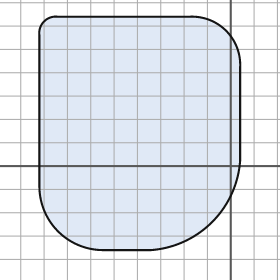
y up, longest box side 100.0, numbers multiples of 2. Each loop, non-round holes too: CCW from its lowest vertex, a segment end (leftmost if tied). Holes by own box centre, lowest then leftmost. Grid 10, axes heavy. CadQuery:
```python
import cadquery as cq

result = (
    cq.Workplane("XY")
    .moveTo(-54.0, -36.0)
    .lineTo(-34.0, -36.0)
    .threePointArc((-8.0, -24.0), (4.0, 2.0))
    .lineTo(4.0, 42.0)
    .threePointArc((-2.0, 58.0), (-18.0, 64.0))
    .lineTo(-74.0, 64.0)
    .threePointArc((-80.0, 62.0), (-82.0, 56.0))
    .lineTo(-82.0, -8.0)
    .threePointArc((-74.0, -28.0), (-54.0, -36.0))
    .close()
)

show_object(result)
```